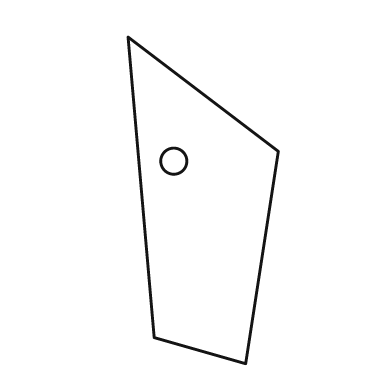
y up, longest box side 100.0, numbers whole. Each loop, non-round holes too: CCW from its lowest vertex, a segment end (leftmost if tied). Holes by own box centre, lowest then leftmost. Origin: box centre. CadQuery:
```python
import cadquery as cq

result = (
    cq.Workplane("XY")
    .moveTo(13.0, -50.0)
    .lineTo(23.0, 15.0)
    .lineTo(-23.0, 50.0)
    .lineTo(-15.0, -42.0)
    .close()
    .moveTo(-9.0, 12.0)
    .circle(4.0)
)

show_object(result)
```